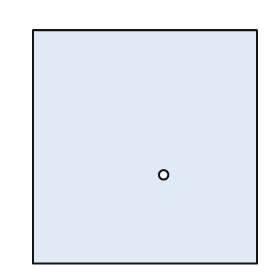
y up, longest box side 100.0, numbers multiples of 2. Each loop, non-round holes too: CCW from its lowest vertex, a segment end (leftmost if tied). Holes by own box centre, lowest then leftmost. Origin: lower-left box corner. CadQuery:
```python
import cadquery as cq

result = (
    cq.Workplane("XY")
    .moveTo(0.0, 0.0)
    .lineTo(96.0, 0.0)
    .lineTo(96.0, 100.0)
    .lineTo(0.0, 100.0)
    .close()
    .moveTo(56.0, 38.0)
    .circle(2.0)
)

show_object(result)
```